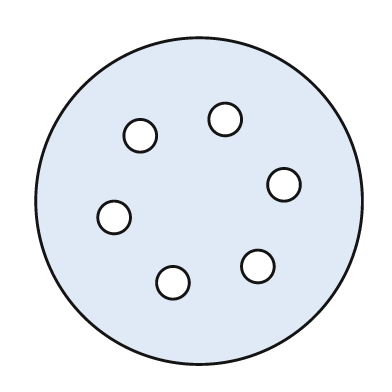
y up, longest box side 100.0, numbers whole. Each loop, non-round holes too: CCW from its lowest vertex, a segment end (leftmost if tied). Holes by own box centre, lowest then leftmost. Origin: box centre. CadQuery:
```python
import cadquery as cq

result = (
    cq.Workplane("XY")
    .moveTo(0.0, 0.0)
    .circle(50.0)
    .moveTo(-8.0, -25.0)
    .circle(5.0)
    .moveTo(18.0, -20.0)
    .circle(5.0)
    .moveTo(-26.0, -5.0)
    .circle(5.0)
    .moveTo(26.0, 5.0)
    .circle(5.0)
    .moveTo(-18.0, 20.0)
    .circle(5.0)
    .moveTo(8.0, 25.0)
    .circle(5.0)
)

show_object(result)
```